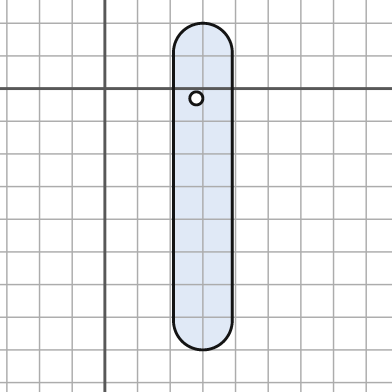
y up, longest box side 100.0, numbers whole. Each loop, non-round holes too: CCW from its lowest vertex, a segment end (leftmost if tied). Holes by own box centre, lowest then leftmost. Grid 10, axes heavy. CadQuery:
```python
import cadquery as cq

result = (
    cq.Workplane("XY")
    .moveTo(21.0, -71.0)
    .threePointArc((30.0, -80.0), (39.0, -71.0))
    .lineTo(39.0, 11.0)
    .threePointArc((30.0, 20.0), (21.0, 11.0))
    .close()
    .moveTo(28.0, -3.0)
    .circle(2.0)
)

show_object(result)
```